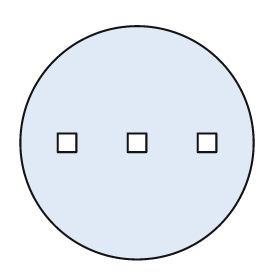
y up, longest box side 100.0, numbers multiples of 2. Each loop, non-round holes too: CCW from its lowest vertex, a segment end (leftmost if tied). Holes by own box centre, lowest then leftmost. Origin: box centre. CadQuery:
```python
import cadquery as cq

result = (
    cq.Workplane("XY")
    .moveTo(0.0, 0.0)
    .circle(50.0)
    .moveTo(-34.0, -4.0)
    .lineTo(-26.0, -4.0)
    .lineTo(-26.0, 4.0)
    .lineTo(-34.0, 4.0)
    .close()
    .moveTo(-4.0, -4.0)
    .lineTo(4.0, -4.0)
    .lineTo(4.0, 4.0)
    .lineTo(-4.0, 4.0)
    .close()
    .moveTo(26.0, -4.0)
    .lineTo(34.0, -4.0)
    .lineTo(34.0, 4.0)
    .lineTo(26.0, 4.0)
    .close()
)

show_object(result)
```